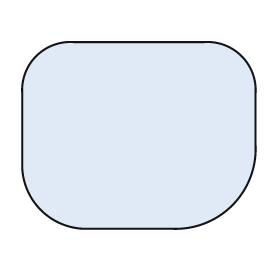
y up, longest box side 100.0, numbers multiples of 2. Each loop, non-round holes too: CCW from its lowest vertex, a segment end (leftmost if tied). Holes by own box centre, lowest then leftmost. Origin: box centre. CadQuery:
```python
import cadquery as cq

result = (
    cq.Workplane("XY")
    .moveTo(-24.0, -40.0)
    .lineTo(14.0, -40.0)
    .threePointArc((40.0, -30.0), (50.0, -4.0))
    .lineTo(50.0, 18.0)
    .threePointArc((44.0, 34.0), (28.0, 40.0))
    .lineTo(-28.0, 40.0)
    .threePointArc((-44.0, 34.0), (-50.0, 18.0))
    .lineTo(-50.0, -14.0)
    .threePointArc((-42.0, -32.0), (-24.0, -40.0))
    .close()
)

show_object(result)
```